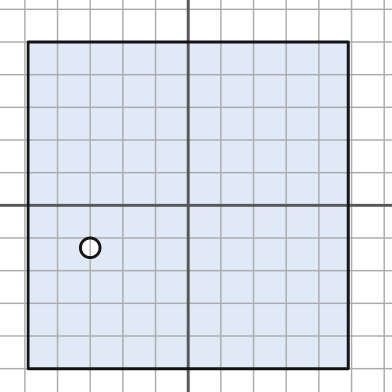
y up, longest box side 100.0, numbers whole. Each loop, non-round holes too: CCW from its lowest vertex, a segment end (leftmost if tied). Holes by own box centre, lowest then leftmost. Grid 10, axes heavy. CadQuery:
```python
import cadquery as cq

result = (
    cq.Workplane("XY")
    .moveTo(-49.0, -50.0)
    .lineTo(49.0, -50.0)
    .lineTo(49.0, 50.0)
    .lineTo(-49.0, 50.0)
    .close()
    .moveTo(-30.0, -13.0)
    .circle(3.0)
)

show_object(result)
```